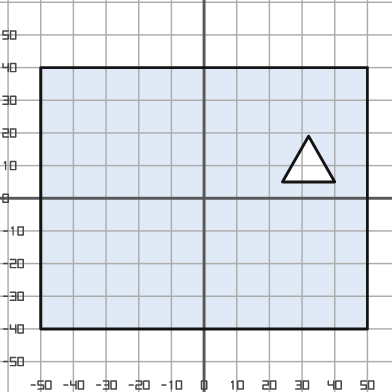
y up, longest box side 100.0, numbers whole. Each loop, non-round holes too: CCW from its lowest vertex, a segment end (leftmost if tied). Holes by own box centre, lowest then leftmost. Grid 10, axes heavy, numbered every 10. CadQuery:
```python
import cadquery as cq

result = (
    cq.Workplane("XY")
    .moveTo(-50.0, -40.0)
    .lineTo(50.0, -40.0)
    .lineTo(50.0, 40.0)
    .lineTo(-50.0, 40.0)
    .close()
    .moveTo(24.0, 5.0)
    .lineTo(40.0, 5.0)
    .lineTo(32.0, 19.0)
    .close()
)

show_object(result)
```